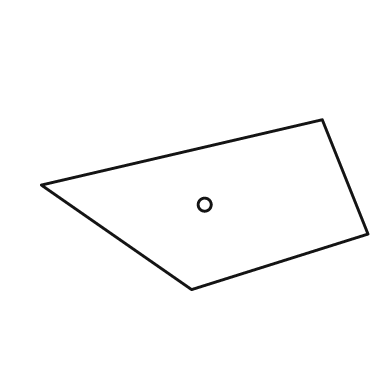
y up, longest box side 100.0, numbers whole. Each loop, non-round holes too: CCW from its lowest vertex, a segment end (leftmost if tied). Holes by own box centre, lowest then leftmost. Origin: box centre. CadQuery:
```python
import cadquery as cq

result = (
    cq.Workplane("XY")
    .moveTo(-4.0, -26.0)
    .lineTo(50.0, -9.0)
    .lineTo(36.0, 26.0)
    .lineTo(-50.0, 6.0)
    .close()
    .moveTo(0.0, 0.0)
    .circle(2.0)
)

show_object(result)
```